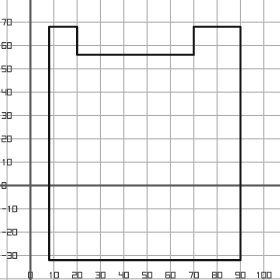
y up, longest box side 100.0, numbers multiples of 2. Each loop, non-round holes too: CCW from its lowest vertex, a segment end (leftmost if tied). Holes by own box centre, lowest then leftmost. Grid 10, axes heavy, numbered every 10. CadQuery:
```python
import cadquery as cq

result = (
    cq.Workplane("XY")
    .moveTo(8.0, -32.0)
    .lineTo(90.0, -32.0)
    .lineTo(90.0, 68.0)
    .lineTo(70.0, 68.0)
    .lineTo(70.0, 56.0)
    .lineTo(20.0, 56.0)
    .lineTo(20.0, 68.0)
    .lineTo(8.0, 68.0)
    .close()
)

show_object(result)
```